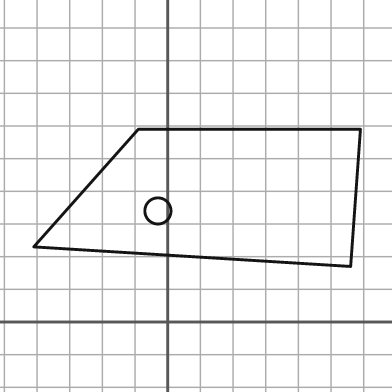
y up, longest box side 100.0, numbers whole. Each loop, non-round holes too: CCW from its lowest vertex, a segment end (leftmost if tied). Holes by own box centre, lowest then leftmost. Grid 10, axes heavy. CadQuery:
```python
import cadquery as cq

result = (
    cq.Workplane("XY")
    .moveTo(56.0, 17.0)
    .lineTo(59.0, 59.0)
    .lineTo(-9.0, 59.0)
    .lineTo(-41.0, 23.0)
    .close()
    .moveTo(-3.0, 34.0)
    .circle(4.0)
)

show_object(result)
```